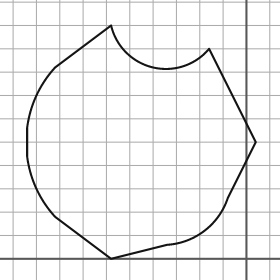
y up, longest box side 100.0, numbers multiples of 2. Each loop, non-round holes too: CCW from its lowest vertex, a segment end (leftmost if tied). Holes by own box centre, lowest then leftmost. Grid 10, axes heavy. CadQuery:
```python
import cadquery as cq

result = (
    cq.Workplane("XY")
    .moveTo(-58.0, 0.0)
    .lineTo(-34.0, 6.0)
    .threePointArc((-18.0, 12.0), (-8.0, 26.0))
    .lineTo(4.0, 50.0)
    .lineTo(-16.0, 90.0)
    .threePointArc((-40.0, 82.0), (-58.0, 100.0))
    .lineTo(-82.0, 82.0)
    .threePointArc((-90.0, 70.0), (-94.0, 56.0))
    .lineTo(-94.0, 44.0)
    .threePointArc((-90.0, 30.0), (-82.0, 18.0))
    .close()
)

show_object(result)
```